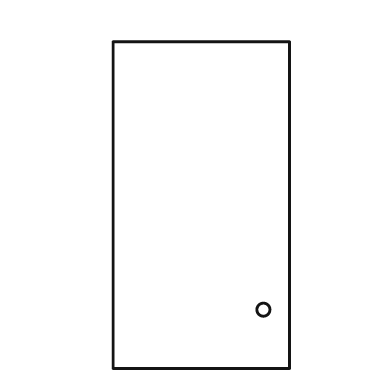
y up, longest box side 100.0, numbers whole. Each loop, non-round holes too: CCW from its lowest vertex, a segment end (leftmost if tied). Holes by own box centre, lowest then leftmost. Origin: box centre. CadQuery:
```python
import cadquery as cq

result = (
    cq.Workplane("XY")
    .moveTo(-27.0, -50.0)
    .lineTo(27.0, -50.0)
    .lineTo(27.0, 50.0)
    .lineTo(-27.0, 50.0)
    .close()
    .moveTo(19.0, -32.0)
    .circle(2.0)
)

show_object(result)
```